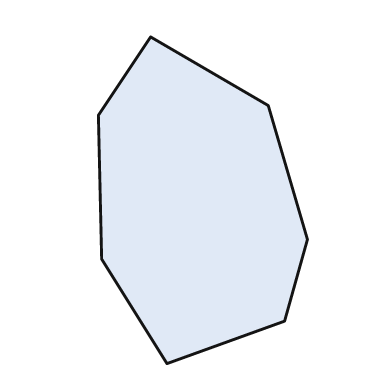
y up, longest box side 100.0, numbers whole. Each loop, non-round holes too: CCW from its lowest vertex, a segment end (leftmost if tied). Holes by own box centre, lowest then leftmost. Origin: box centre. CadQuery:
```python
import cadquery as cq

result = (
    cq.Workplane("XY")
    .moveTo(-11.0, -50.0)
    .lineTo(25.0, -37.0)
    .lineTo(32.0, -12.0)
    .lineTo(20.0, 29.0)
    .lineTo(-16.0, 50.0)
    .lineTo(-32.0, 26.0)
    .lineTo(-31.0, -18.0)
    .close()
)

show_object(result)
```